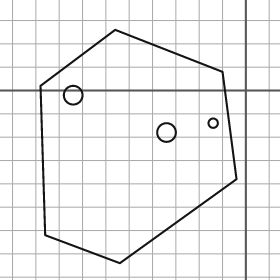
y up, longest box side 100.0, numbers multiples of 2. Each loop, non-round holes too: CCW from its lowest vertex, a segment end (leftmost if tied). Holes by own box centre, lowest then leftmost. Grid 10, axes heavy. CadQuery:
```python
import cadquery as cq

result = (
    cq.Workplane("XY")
    .moveTo(-54.0, -74.0)
    .lineTo(-4.0, -38.0)
    .lineTo(-10.0, 8.0)
    .lineTo(-56.0, 26.0)
    .lineTo(-88.0, 2.0)
    .lineTo(-86.0, -62.0)
    .close()
    .moveTo(-34.0, -18.0)
    .circle(4.0)
    .moveTo(-14.0, -14.0)
    .circle(2.0)
    .moveTo(-74.0, -2.0)
    .circle(4.0)
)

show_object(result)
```